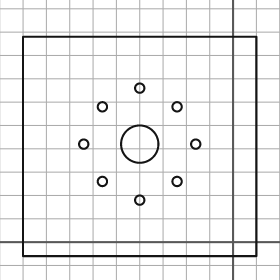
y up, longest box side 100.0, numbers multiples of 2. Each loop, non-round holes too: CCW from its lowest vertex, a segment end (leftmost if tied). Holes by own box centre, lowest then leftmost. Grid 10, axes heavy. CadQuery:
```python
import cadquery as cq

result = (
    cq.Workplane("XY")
    .moveTo(-90.0, -6.0)
    .lineTo(10.0, -6.0)
    .lineTo(10.0, 88.0)
    .lineTo(-90.0, 88.0)
    .close()
    .moveTo(-40.0, 18.0)
    .circle(2.0)
    .moveTo(-56.0, 26.0)
    .circle(2.0)
    .moveTo(-24.0, 26.0)
    .circle(2.0)
    .moveTo(-64.0, 42.0)
    .circle(2.0)
    .moveTo(-40.0, 42.0)
    .circle(8.0)
    .moveTo(-16.0, 42.0)
    .circle(2.0)
    .moveTo(-56.0, 58.0)
    .circle(2.0)
    .moveTo(-24.0, 58.0)
    .circle(2.0)
    .moveTo(-40.0, 66.0)
    .circle(2.0)
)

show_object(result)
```